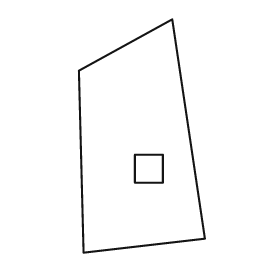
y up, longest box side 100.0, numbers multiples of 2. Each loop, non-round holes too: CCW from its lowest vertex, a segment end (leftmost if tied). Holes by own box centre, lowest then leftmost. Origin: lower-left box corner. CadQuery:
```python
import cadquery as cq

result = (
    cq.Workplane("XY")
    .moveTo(2.0, 0.0)
    .lineTo(54.0, 6.0)
    .lineTo(40.0, 100.0)
    .lineTo(0.0, 78.0)
    .close()
    .moveTo(24.0, 30.0)
    .lineTo(36.0, 30.0)
    .lineTo(36.0, 42.0)
    .lineTo(24.0, 42.0)
    .close()
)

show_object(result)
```